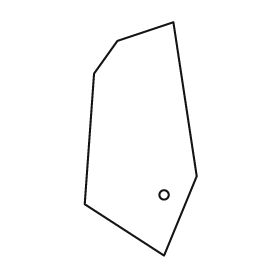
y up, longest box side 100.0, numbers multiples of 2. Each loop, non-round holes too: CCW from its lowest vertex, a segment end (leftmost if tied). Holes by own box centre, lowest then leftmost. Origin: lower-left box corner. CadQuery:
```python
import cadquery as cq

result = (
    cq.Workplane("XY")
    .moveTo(34.0, 0.0)
    .lineTo(48.0, 34.0)
    .lineTo(38.0, 100.0)
    .lineTo(14.0, 92.0)
    .lineTo(4.0, 78.0)
    .lineTo(0.0, 22.0)
    .close()
    .moveTo(34.0, 26.0)
    .circle(2.0)
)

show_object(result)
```